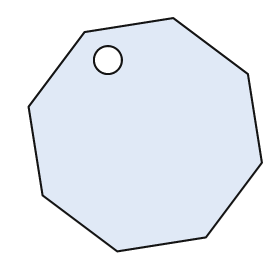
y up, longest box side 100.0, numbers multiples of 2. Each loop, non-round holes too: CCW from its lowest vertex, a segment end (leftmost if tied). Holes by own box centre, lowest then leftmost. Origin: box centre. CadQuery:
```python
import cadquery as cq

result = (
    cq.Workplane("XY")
    .moveTo(-12.0, -50.0)
    .lineTo(26.0, -44.0)
    .lineTo(50.0, -12.0)
    .lineTo(44.0, 26.0)
    .lineTo(12.0, 50.0)
    .lineTo(-26.0, 44.0)
    .lineTo(-50.0, 12.0)
    .lineTo(-44.0, -26.0)
    .close()
    .moveTo(-16.0, 32.0)
    .circle(6.0)
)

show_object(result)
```